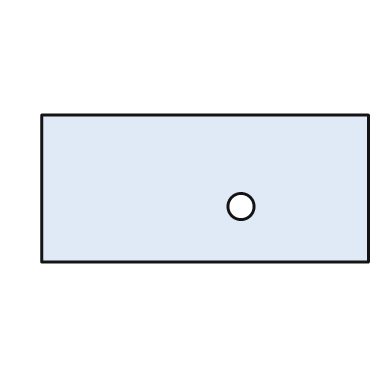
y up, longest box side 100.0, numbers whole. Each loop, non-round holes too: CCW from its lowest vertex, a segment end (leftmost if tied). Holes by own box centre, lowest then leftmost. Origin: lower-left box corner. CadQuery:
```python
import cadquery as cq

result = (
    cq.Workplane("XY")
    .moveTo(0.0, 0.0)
    .lineTo(100.0, 0.0)
    .lineTo(100.0, 45.0)
    .lineTo(0.0, 45.0)
    .close()
    .moveTo(61.0, 17.0)
    .circle(4.0)
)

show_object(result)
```